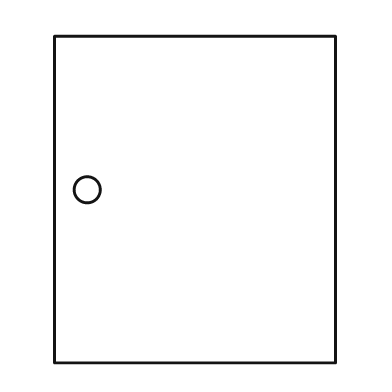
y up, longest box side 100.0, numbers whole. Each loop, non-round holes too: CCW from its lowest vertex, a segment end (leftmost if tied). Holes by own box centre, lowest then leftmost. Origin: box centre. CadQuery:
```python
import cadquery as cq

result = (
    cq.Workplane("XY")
    .moveTo(-43.0, -50.0)
    .lineTo(43.0, -50.0)
    .lineTo(43.0, 50.0)
    .lineTo(-43.0, 50.0)
    .close()
    .moveTo(-33.0, 3.0)
    .circle(4.0)
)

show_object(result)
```